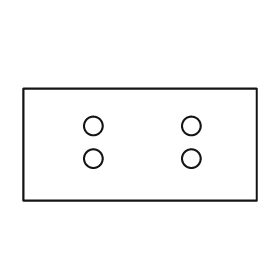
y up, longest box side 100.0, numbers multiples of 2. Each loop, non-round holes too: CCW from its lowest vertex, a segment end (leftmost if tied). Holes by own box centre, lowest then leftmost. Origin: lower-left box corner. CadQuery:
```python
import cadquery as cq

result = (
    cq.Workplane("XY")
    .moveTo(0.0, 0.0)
    .lineTo(100.0, 0.0)
    .lineTo(100.0, 48.0)
    .lineTo(0.0, 48.0)
    .close()
    .moveTo(30.0, 18.0)
    .circle(4.0)
    .moveTo(72.0, 18.0)
    .circle(4.0)
    .moveTo(30.0, 32.0)
    .circle(4.0)
    .moveTo(72.0, 32.0)
    .circle(4.0)
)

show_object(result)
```